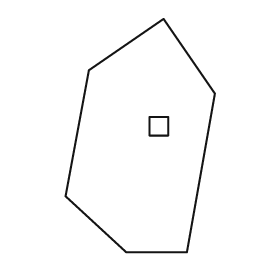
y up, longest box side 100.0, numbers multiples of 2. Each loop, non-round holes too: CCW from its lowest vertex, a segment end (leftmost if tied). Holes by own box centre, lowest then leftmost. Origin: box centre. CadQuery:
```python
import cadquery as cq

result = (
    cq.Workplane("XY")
    .moveTo(-6.0, -50.0)
    .lineTo(20.0, -50.0)
    .lineTo(32.0, 18.0)
    .lineTo(10.0, 50.0)
    .lineTo(-22.0, 28.0)
    .lineTo(-32.0, -26.0)
    .close()
    .moveTo(4.0, 0.0)
    .lineTo(12.0, 0.0)
    .lineTo(12.0, 8.0)
    .lineTo(4.0, 8.0)
    .close()
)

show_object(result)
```